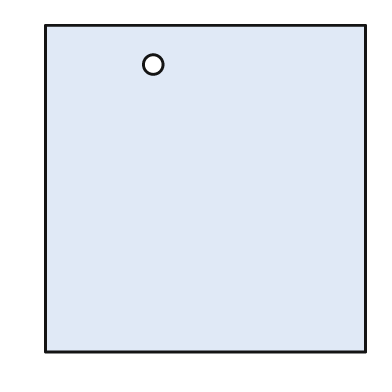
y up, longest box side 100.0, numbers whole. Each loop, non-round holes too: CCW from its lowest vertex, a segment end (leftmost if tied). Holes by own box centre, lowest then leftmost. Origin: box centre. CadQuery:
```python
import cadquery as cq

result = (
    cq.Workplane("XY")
    .moveTo(-49.0, -50.0)
    .lineTo(49.0, -50.0)
    .lineTo(49.0, 50.0)
    .lineTo(-49.0, 50.0)
    .close()
    .moveTo(-16.0, 38.0)
    .circle(3.0)
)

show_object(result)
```